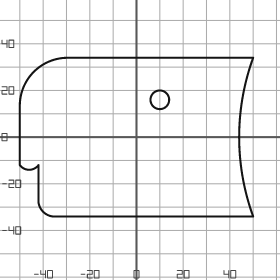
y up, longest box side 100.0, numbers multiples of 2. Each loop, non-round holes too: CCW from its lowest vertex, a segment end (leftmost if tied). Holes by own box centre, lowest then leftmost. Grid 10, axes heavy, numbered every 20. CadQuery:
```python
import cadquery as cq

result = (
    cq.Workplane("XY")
    .moveTo(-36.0, -34.0)
    .lineTo(50.0, -34.0)
    .threePointArc((44.0, 0.0), (50.0, 34.0))
    .lineTo(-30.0, 34.0)
    .threePointArc((-44.0, 28.0), (-50.0, 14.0))
    .lineTo(-50.0, -12.0)
    .threePointArc((-46.0, -14.0), (-42.0, -12.0))
    .lineTo(-42.0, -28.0)
    .threePointArc((-40.0, -32.0), (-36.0, -34.0))
    .close()
    .moveTo(10.0, 16.0)
    .circle(4.0)
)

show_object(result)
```